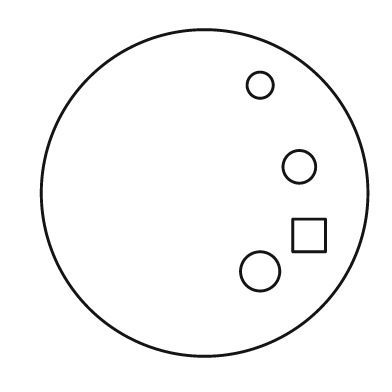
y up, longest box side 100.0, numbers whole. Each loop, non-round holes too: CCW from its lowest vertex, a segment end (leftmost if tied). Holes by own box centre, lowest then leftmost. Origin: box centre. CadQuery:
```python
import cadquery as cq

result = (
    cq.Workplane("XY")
    .moveTo(0.0, 0.0)
    .circle(50.0)
    .moveTo(17.0, -24.0)
    .circle(6.0)
    .moveTo(27.0, -18.0)
    .lineTo(37.0, -18.0)
    .lineTo(37.0, -8.0)
    .lineTo(27.0, -8.0)
    .close()
    .moveTo(29.0, 8.0)
    .circle(5.0)
    .moveTo(17.0, 33.0)
    .circle(4.0)
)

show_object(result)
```